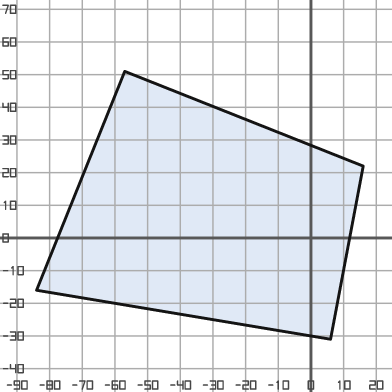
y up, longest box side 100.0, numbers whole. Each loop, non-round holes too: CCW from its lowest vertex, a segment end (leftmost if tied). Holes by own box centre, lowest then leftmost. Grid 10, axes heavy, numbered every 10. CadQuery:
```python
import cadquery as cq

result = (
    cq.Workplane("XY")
    .moveTo(6.0, -31.0)
    .lineTo(16.0, 22.0)
    .lineTo(-57.0, 51.0)
    .lineTo(-84.0, -16.0)
    .close()
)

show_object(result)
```